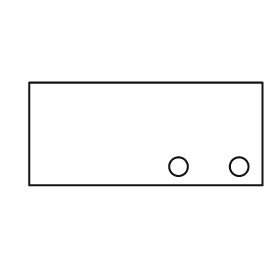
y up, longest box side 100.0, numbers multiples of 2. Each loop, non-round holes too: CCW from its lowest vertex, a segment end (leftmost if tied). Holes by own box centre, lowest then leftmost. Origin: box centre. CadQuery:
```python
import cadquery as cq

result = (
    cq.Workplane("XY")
    .moveTo(-50.0, -22.0)
    .lineTo(50.0, -22.0)
    .lineTo(50.0, 22.0)
    .lineTo(-50.0, 22.0)
    .close()
    .moveTo(14.0, -14.0)
    .circle(4.0)
    .moveTo(40.0, -14.0)
    .circle(4.0)
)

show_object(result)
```